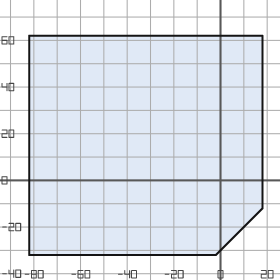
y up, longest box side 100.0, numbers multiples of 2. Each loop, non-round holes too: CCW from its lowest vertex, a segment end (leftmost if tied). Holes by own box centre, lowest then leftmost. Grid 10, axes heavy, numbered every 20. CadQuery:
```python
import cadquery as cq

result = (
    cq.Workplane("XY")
    .moveTo(-82.0, -32.0)
    .lineTo(-2.0, -32.0)
    .lineTo(18.0, -12.0)
    .lineTo(18.0, 62.0)
    .lineTo(-82.0, 62.0)
    .close()
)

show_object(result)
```